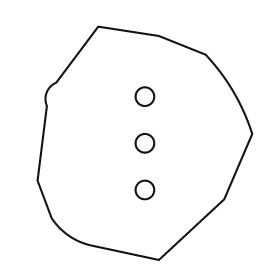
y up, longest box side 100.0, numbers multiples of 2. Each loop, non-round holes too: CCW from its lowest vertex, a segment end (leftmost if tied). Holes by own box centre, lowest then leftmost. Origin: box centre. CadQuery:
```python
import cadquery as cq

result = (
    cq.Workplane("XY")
    .moveTo(6.0, -50.0)
    .lineTo(34.0, -24.0)
    .lineTo(46.0, 4.0)
    .threePointArc((38.0, 22.0), (26.0, 38.0))
    .lineTo(6.0, 46.0)
    .lineTo(-20.0, 50.0)
    .lineTo(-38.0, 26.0)
    .threePointArc((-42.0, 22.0), (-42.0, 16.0))
    .lineTo(-46.0, -16.0)
    .lineTo(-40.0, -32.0)
    .threePointArc((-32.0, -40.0), (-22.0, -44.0))
    .close()
    .moveTo(0.0, -20.0)
    .circle(4.0)
    .moveTo(0.0, 0.0)
    .circle(4.0)
    .moveTo(0.0, 20.0)
    .circle(4.0)
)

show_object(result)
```